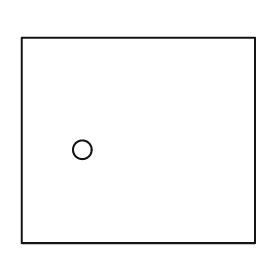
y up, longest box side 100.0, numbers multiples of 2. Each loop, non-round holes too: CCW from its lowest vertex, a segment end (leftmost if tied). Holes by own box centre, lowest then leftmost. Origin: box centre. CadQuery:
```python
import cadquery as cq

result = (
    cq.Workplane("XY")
    .moveTo(-50.0, -44.0)
    .lineTo(50.0, -44.0)
    .lineTo(50.0, 44.0)
    .lineTo(-50.0, 44.0)
    .close()
    .moveTo(-24.0, -4.0)
    .circle(4.0)
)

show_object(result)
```